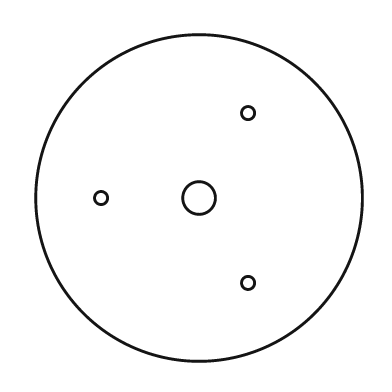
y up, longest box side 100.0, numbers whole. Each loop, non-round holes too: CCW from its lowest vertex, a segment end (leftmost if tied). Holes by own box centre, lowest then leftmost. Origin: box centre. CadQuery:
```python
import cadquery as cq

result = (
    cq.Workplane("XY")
    .moveTo(0.0, 0.0)
    .circle(50.0)
    .moveTo(15.0, -26.0)
    .circle(2.0)
    .moveTo(-30.0, 0.0)
    .circle(2.0)
    .moveTo(0.0, 0.0)
    .circle(5.0)
    .moveTo(15.0, 26.0)
    .circle(2.0)
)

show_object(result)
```